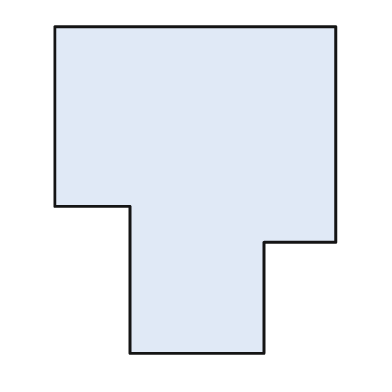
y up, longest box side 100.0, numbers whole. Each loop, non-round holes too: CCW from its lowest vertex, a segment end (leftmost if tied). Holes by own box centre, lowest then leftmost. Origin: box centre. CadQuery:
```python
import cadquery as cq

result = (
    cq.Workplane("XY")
    .moveTo(-20.0, -50.0)
    .lineTo(21.0, -50.0)
    .lineTo(21.0, -16.0)
    .lineTo(43.0, -16.0)
    .lineTo(43.0, 50.0)
    .lineTo(-43.0, 50.0)
    .lineTo(-43.0, -5.0)
    .lineTo(-20.0, -5.0)
    .close()
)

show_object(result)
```